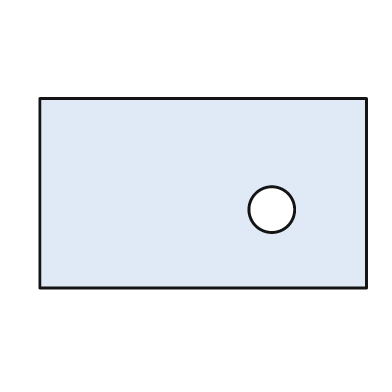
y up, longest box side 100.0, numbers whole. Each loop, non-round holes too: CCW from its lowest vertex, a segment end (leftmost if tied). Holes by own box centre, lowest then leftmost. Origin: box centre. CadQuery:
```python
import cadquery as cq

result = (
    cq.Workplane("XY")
    .moveTo(-50.0, -29.0)
    .lineTo(50.0, -29.0)
    .lineTo(50.0, 29.0)
    .lineTo(-50.0, 29.0)
    .close()
    .moveTo(21.0, -5.0)
    .circle(7.0)
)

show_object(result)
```